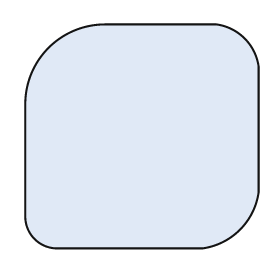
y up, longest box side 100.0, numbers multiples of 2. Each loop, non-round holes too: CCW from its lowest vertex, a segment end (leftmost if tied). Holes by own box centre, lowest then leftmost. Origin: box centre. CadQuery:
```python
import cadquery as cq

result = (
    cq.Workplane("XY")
    .moveTo(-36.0, -48.0)
    .lineTo(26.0, -48.0)
    .threePointArc((42.0, -40.0), (50.0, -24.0))
    .lineTo(50.0, 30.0)
    .threePointArc((44.0, 42.0), (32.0, 48.0))
    .lineTo(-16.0, 48.0)
    .threePointArc((-40.0, 38.0), (-50.0, 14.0))
    .lineTo(-50.0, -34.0)
    .threePointArc((-46.0, -44.0), (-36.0, -48.0))
    .close()
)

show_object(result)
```